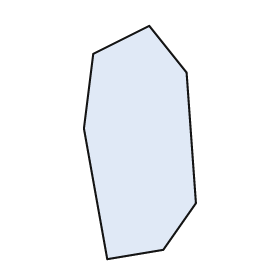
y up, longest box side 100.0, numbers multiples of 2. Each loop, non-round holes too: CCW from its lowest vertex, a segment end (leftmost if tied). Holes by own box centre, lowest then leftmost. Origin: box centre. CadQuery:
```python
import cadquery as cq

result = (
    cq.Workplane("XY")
    .moveTo(-14.0, -50.0)
    .lineTo(10.0, -46.0)
    .lineTo(24.0, -26.0)
    .lineTo(20.0, 30.0)
    .lineTo(4.0, 50.0)
    .lineTo(-20.0, 38.0)
    .lineTo(-24.0, 6.0)
    .close()
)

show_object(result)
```